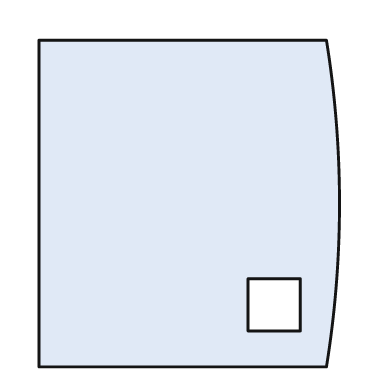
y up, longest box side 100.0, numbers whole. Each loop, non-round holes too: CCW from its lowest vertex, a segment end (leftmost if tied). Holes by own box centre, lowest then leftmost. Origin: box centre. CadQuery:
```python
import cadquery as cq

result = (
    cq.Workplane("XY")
    .moveTo(-46.0, -50.0)
    .lineTo(42.0, -50.0)
    .threePointArc((46.0, 0.0), (42.0, 50.0))
    .lineTo(-46.0, 50.0)
    .close()
    .moveTo(18.0, -39.0)
    .lineTo(34.0, -39.0)
    .lineTo(34.0, -23.0)
    .lineTo(18.0, -23.0)
    .close()
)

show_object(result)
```